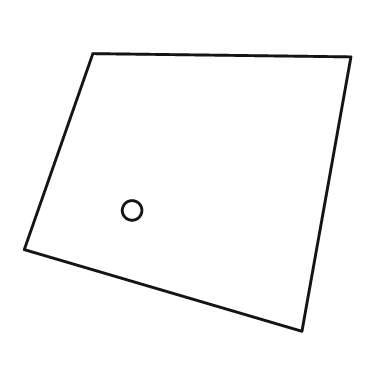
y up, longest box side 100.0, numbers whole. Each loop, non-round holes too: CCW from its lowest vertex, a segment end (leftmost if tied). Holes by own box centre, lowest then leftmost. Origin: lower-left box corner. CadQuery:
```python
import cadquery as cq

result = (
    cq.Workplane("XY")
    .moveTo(85.0, 0.0)
    .lineTo(100.0, 84.0)
    .lineTo(21.0, 85.0)
    .lineTo(0.0, 25.0)
    .close()
    .moveTo(33.0, 37.0)
    .circle(3.0)
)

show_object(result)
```